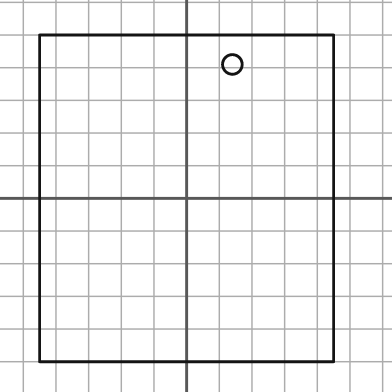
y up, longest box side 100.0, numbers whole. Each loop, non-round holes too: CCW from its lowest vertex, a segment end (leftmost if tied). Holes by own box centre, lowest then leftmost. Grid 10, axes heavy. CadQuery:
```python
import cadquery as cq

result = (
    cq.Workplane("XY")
    .moveTo(-45.0, -50.0)
    .lineTo(45.0, -50.0)
    .lineTo(45.0, 50.0)
    .lineTo(-45.0, 50.0)
    .close()
    .moveTo(14.0, 41.0)
    .circle(3.0)
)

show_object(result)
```